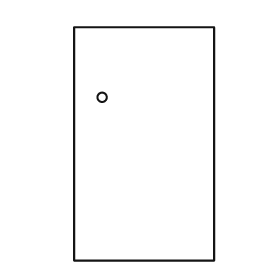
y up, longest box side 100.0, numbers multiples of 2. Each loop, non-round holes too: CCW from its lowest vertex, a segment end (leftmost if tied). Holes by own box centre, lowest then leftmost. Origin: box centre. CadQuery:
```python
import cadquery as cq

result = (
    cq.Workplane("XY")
    .moveTo(-30.0, -50.0)
    .lineTo(30.0, -50.0)
    .lineTo(30.0, 50.0)
    .lineTo(-30.0, 50.0)
    .close()
    .moveTo(-18.0, 20.0)
    .circle(2.0)
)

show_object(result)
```